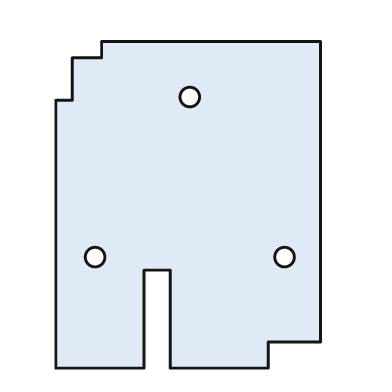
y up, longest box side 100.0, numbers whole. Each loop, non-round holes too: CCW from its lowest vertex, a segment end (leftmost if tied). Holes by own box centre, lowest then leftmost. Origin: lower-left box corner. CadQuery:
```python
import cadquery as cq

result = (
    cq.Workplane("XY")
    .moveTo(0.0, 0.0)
    .lineTo(27.0, 0.0)
    .lineTo(27.0, 30.0)
    .lineTo(35.0, 30.0)
    .lineTo(35.0, 0.0)
    .lineTo(65.0, 0.0)
    .lineTo(65.0, 8.0)
    .lineTo(81.0, 8.0)
    .lineTo(81.0, 100.0)
    .lineTo(14.0, 100.0)
    .lineTo(14.0, 95.0)
    .lineTo(5.0, 95.0)
    .lineTo(5.0, 82.0)
    .lineTo(0.0, 82.0)
    .close()
    .moveTo(12.0, 34.0)
    .circle(3.0)
    .moveTo(70.0, 34.0)
    .circle(3.0)
    .moveTo(41.0, 83.0)
    .circle(3.0)
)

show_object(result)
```